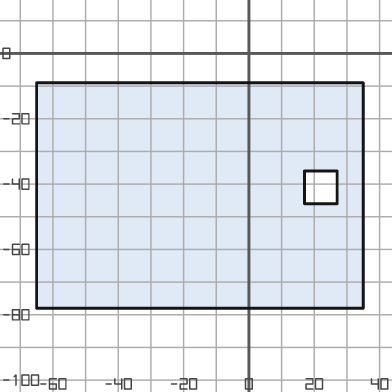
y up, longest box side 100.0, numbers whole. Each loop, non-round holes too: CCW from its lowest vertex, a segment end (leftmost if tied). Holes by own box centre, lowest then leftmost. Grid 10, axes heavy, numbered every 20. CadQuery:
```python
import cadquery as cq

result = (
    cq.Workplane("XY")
    .moveTo(-65.0, -78.0)
    .lineTo(35.0, -78.0)
    .lineTo(35.0, -9.0)
    .lineTo(-65.0, -9.0)
    .close()
    .moveTo(17.0, -46.0)
    .lineTo(27.0, -46.0)
    .lineTo(27.0, -36.0)
    .lineTo(17.0, -36.0)
    .close()
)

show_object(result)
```